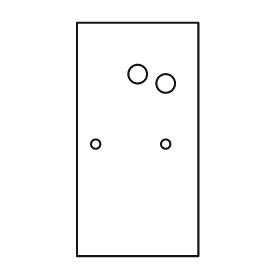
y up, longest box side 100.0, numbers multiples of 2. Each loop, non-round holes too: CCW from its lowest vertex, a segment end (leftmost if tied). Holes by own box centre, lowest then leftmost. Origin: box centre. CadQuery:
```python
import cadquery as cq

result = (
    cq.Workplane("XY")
    .moveTo(-26.0, -50.0)
    .lineTo(26.0, -50.0)
    .lineTo(26.0, 50.0)
    .lineTo(-26.0, 50.0)
    .close()
    .moveTo(-18.0, -2.0)
    .circle(2.0)
    .moveTo(12.0, -2.0)
    .circle(2.0)
    .moveTo(12.0, 24.0)
    .circle(4.0)
    .moveTo(0.0, 28.0)
    .circle(4.0)
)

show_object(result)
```